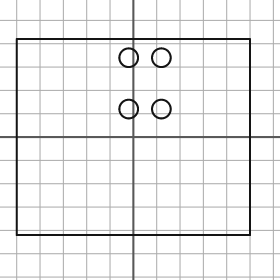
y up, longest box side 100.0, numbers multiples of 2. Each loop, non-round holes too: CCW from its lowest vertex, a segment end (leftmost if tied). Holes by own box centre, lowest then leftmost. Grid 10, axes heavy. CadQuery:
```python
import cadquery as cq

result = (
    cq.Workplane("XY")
    .moveTo(-50.0, -42.0)
    .lineTo(50.0, -42.0)
    .lineTo(50.0, 42.0)
    .lineTo(-50.0, 42.0)
    .close()
    .moveTo(-2.0, 12.0)
    .circle(4.0)
    .moveTo(12.0, 12.0)
    .circle(4.0)
    .moveTo(-2.0, 34.0)
    .circle(4.0)
    .moveTo(12.0, 34.0)
    .circle(4.0)
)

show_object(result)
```